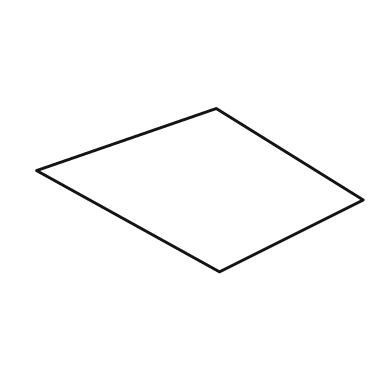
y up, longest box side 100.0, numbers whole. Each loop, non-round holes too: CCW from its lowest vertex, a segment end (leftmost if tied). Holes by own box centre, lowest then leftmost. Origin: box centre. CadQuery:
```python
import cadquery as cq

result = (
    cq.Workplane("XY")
    .moveTo(6.0, -25.0)
    .lineTo(50.0, -3.0)
    .lineTo(5.0, 25.0)
    .lineTo(-50.0, 6.0)
    .close()
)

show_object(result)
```